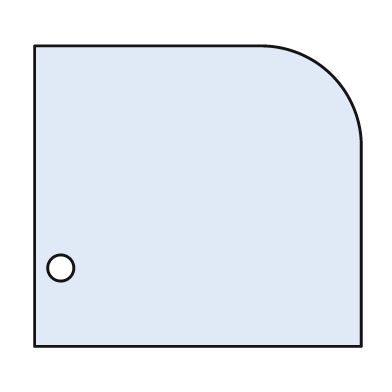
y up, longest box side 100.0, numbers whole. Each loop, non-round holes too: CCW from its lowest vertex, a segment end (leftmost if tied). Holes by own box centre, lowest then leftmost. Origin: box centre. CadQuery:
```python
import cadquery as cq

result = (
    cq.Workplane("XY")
    .moveTo(-50.0, -46.0)
    .lineTo(50.0, -46.0)
    .lineTo(50.0, 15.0)
    .threePointArc((41.0, 37.0), (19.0, 46.0))
    .lineTo(-50.0, 46.0)
    .close()
    .moveTo(-42.0, -22.0)
    .circle(4.0)
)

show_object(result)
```